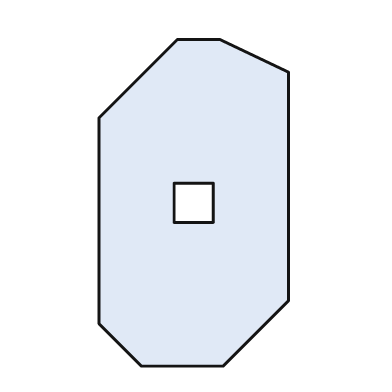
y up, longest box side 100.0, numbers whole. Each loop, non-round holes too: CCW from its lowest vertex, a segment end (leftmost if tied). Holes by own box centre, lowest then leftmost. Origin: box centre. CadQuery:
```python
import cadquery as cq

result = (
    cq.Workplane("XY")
    .moveTo(-16.0, -50.0)
    .lineTo(9.0, -50.0)
    .lineTo(29.0, -30.0)
    .lineTo(29.0, 40.0)
    .lineTo(8.0, 50.0)
    .lineTo(-5.0, 50.0)
    .lineTo(-29.0, 26.0)
    .lineTo(-29.0, -37.0)
    .close()
    .moveTo(-6.0, -6.0)
    .lineTo(6.0, -6.0)
    .lineTo(6.0, 6.0)
    .lineTo(-6.0, 6.0)
    .close()
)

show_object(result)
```